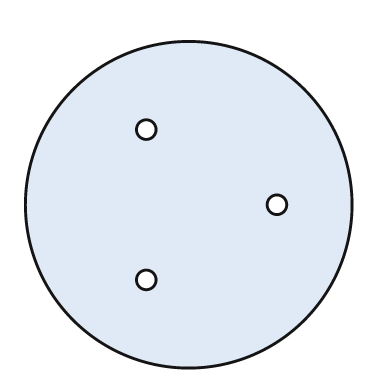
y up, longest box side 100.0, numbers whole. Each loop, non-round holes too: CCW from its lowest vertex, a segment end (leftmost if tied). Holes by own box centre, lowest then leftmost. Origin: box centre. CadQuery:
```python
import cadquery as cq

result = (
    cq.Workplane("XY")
    .moveTo(0.0, 0.0)
    .circle(50.0)
    .moveTo(-13.0, -23.0)
    .circle(3.0)
    .moveTo(27.0, 0.0)
    .circle(3.0)
    .moveTo(-13.0, 23.0)
    .circle(3.0)
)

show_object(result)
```